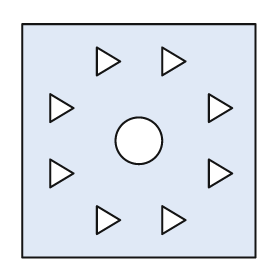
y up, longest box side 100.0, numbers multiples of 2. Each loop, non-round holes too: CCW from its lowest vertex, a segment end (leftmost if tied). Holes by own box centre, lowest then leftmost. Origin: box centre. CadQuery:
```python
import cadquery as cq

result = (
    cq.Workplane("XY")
    .moveTo(-50.0, -50.0)
    .lineTo(50.0, -50.0)
    .lineTo(50.0, 50.0)
    .lineTo(-50.0, 50.0)
    .close()
    .moveTo(-18.0, -40.0)
    .lineTo(-8.0, -34.0)
    .lineTo(-18.0, -28.0)
    .close()
    .moveTo(10.0, -40.0)
    .lineTo(20.0, -34.0)
    .lineTo(10.0, -28.0)
    .close()
    .moveTo(-38.0, -20.0)
    .lineTo(-28.0, -14.0)
    .lineTo(-38.0, -8.0)
    .close()
    .moveTo(30.0, -20.0)
    .lineTo(40.0, -14.0)
    .lineTo(30.0, -8.0)
    .close()
    .moveTo(0.0, 0.0)
    .circle(10.0)
    .moveTo(-38.0, 8.0)
    .lineTo(-28.0, 14.0)
    .lineTo(-38.0, 20.0)
    .close()
    .moveTo(30.0, 8.0)
    .lineTo(40.0, 14.0)
    .lineTo(30.0, 20.0)
    .close()
    .moveTo(-18.0, 28.0)
    .lineTo(-8.0, 34.0)
    .lineTo(-18.0, 40.0)
    .close()
    .moveTo(10.0, 28.0)
    .lineTo(20.0, 34.0)
    .lineTo(10.0, 40.0)
    .close()
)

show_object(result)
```